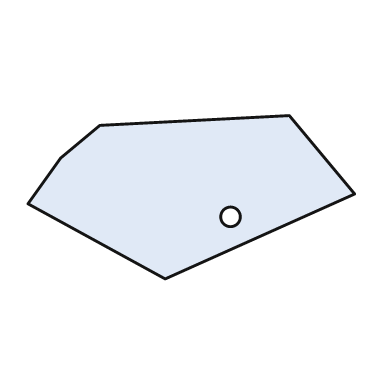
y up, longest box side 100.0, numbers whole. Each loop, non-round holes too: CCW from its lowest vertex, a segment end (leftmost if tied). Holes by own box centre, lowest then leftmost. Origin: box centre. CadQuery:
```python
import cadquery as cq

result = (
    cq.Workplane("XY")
    .moveTo(-8.0, -25.0)
    .lineTo(50.0, 1.0)
    .lineTo(30.0, 25.0)
    .lineTo(-28.0, 22.0)
    .lineTo(-40.0, 12.0)
    .lineTo(-50.0, -2.0)
    .close()
    .moveTo(12.0, -6.0)
    .circle(3.0)
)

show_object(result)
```